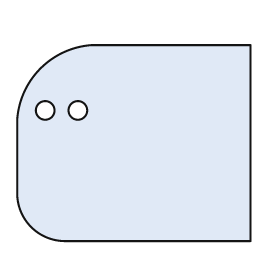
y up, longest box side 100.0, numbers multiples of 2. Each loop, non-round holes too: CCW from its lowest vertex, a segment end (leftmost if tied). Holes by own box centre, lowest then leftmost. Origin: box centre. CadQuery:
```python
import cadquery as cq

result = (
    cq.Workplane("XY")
    .moveTo(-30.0, -42.0)
    .lineTo(50.0, -42.0)
    .lineTo(50.0, 42.0)
    .lineTo(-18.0, 42.0)
    .threePointArc((-40.0, 32.0), (-50.0, 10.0))
    .lineTo(-50.0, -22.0)
    .threePointArc((-44.0, -36.0), (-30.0, -42.0))
    .close()
    .moveTo(-38.0, 14.0)
    .circle(4.0)
    .moveTo(-24.0, 14.0)
    .circle(4.0)
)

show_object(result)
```